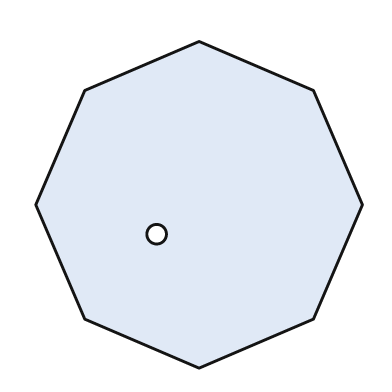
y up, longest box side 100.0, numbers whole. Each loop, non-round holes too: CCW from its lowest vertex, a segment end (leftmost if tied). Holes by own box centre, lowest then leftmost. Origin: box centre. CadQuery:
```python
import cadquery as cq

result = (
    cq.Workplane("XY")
    .moveTo(0.0, -50.0)
    .lineTo(35.0, -35.0)
    .lineTo(50.0, 0.0)
    .lineTo(35.0, 35.0)
    .lineTo(0.0, 50.0)
    .lineTo(-35.0, 35.0)
    .lineTo(-50.0, 0.0)
    .lineTo(-35.0, -35.0)
    .close()
    .moveTo(-13.0, -9.0)
    .circle(3.0)
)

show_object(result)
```